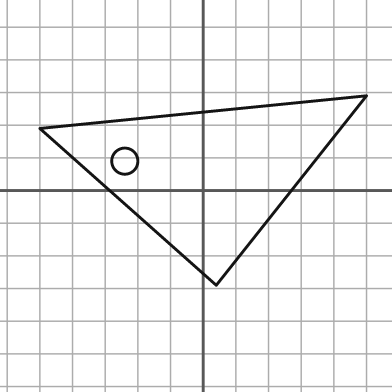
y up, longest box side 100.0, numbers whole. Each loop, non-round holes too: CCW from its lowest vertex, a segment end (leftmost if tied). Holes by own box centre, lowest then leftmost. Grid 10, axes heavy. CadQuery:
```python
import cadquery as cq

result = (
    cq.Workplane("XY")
    .moveTo(4.0, -29.0)
    .lineTo(50.0, 29.0)
    .lineTo(-50.0, 19.0)
    .close()
    .moveTo(-24.0, 9.0)
    .circle(4.0)
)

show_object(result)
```